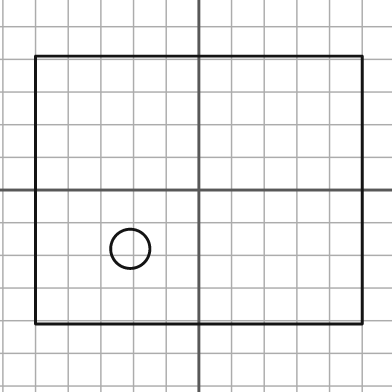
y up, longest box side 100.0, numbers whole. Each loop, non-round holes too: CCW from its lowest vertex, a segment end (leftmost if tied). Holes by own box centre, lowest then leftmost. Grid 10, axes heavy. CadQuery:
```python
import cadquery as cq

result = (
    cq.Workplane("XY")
    .moveTo(-50.0, -41.0)
    .lineTo(50.0, -41.0)
    .lineTo(50.0, 41.0)
    .lineTo(-50.0, 41.0)
    .close()
    .moveTo(-21.0, -18.0)
    .circle(6.0)
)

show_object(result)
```